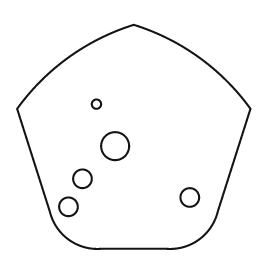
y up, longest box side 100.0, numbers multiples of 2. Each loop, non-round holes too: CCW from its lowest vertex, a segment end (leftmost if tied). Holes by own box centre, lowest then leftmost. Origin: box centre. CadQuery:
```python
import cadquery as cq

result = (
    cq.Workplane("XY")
    .moveTo(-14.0, -48.0)
    .lineTo(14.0, -48.0)
    .threePointArc((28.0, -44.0), (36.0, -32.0))
    .lineTo(50.0, 12.0)
    .threePointArc((28.0, 34.0), (0.0, 48.0))
    .threePointArc((-28.0, 34.0), (-50.0, 12.0))
    .lineTo(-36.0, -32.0)
    .threePointArc((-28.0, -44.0), (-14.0, -48.0))
    .close()
    .moveTo(-28.0, -30.0)
    .circle(4.0)
    .moveTo(24.0, -26.0)
    .circle(4.0)
    .moveTo(-22.0, -18.0)
    .circle(4.0)
    .moveTo(-8.0, -4.0)
    .circle(6.0)
    .moveTo(-16.0, 14.0)
    .circle(2.0)
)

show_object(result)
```